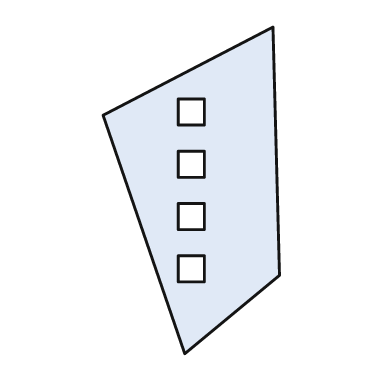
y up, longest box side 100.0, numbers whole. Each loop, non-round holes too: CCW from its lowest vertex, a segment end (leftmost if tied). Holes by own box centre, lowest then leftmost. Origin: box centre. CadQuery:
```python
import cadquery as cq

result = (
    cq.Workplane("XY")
    .moveTo(-2.0, -50.0)
    .lineTo(27.0, -26.0)
    .lineTo(25.0, 50.0)
    .lineTo(-27.0, 23.0)
    .close()
    .moveTo(-4.0, -28.0)
    .lineTo(4.0, -28.0)
    .lineTo(4.0, -20.0)
    .lineTo(-4.0, -20.0)
    .close()
    .moveTo(-4.0, -12.0)
    .lineTo(4.0, -12.0)
    .lineTo(4.0, -4.0)
    .lineTo(-4.0, -4.0)
    .close()
    .moveTo(-4.0, 4.0)
    .lineTo(4.0, 4.0)
    .lineTo(4.0, 12.0)
    .lineTo(-4.0, 12.0)
    .close()
    .moveTo(-4.0, 20.0)
    .lineTo(4.0, 20.0)
    .lineTo(4.0, 28.0)
    .lineTo(-4.0, 28.0)
    .close()
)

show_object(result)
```